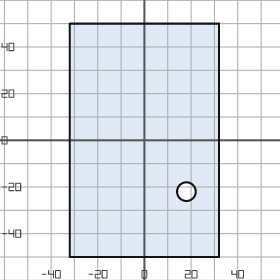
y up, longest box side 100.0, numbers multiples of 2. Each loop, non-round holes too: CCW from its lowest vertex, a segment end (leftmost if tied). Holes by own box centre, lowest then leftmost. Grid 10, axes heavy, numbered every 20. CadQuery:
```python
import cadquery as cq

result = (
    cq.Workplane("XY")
    .moveTo(-32.0, -50.0)
    .lineTo(32.0, -50.0)
    .lineTo(32.0, 50.0)
    .lineTo(-32.0, 50.0)
    .close()
    .moveTo(18.0, -22.0)
    .circle(4.0)
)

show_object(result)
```